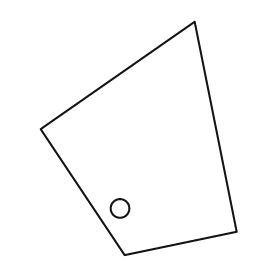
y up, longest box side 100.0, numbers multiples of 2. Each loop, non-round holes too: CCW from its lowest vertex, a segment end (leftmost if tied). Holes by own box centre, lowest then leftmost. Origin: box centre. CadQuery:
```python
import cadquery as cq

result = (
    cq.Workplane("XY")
    .moveTo(-6.0, -50.0)
    .lineTo(42.0, -40.0)
    .lineTo(24.0, 50.0)
    .lineTo(-42.0, 4.0)
    .close()
    .moveTo(-8.0, -30.0)
    .circle(4.0)
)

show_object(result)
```